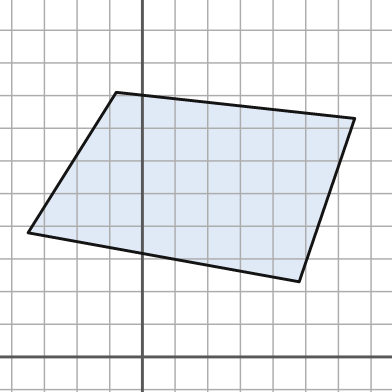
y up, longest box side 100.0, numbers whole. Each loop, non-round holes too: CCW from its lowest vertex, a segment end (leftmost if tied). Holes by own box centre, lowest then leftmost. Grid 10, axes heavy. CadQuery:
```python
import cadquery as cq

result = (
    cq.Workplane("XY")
    .moveTo(48.0, 23.0)
    .lineTo(65.0, 73.0)
    .lineTo(-8.0, 81.0)
    .lineTo(-35.0, 38.0)
    .close()
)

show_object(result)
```